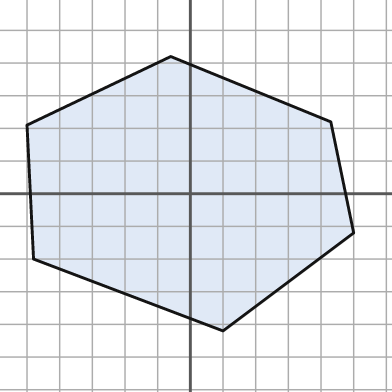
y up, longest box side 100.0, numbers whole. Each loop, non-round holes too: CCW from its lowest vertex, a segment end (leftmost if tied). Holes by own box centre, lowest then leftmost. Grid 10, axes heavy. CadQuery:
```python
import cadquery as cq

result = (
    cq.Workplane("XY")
    .moveTo(10.0, -42.0)
    .lineTo(50.0, -12.0)
    .lineTo(43.0, 22.0)
    .lineTo(-6.0, 42.0)
    .lineTo(-50.0, 21.0)
    .lineTo(-48.0, -20.0)
    .close()
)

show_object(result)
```